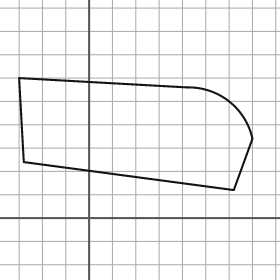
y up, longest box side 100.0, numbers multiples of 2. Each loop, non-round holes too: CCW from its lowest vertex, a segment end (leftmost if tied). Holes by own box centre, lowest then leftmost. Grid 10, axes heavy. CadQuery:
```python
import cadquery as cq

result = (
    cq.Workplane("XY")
    .moveTo(62.0, 12.0)
    .lineTo(70.0, 34.0)
    .threePointArc((60.0, 50.0), (42.0, 56.0))
    .lineTo(-30.0, 60.0)
    .lineTo(-28.0, 24.0)
    .close()
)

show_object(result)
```